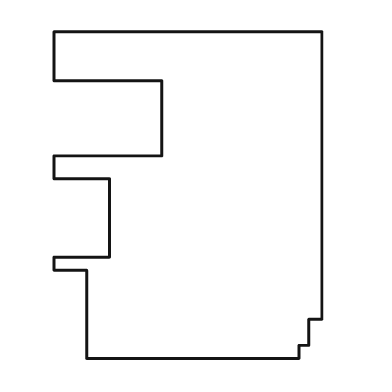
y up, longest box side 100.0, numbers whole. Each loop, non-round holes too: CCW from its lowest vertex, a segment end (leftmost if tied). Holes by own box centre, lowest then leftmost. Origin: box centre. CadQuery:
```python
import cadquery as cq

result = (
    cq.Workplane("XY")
    .moveTo(-31.0, -50.0)
    .lineTo(34.0, -50.0)
    .lineTo(34.0, -46.0)
    .lineTo(37.0, -46.0)
    .lineTo(37.0, -38.0)
    .lineTo(41.0, -38.0)
    .lineTo(41.0, 50.0)
    .lineTo(-41.0, 50.0)
    .lineTo(-41.0, 35.0)
    .lineTo(-8.0, 35.0)
    .lineTo(-8.0, 12.0)
    .lineTo(-41.0, 12.0)
    .lineTo(-41.0, 5.0)
    .lineTo(-24.0, 5.0)
    .lineTo(-24.0, -19.0)
    .lineTo(-41.0, -19.0)
    .lineTo(-41.0, -23.0)
    .lineTo(-31.0, -23.0)
    .close()
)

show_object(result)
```